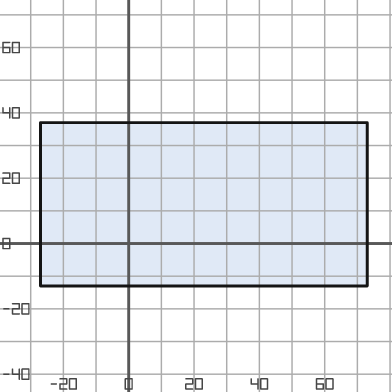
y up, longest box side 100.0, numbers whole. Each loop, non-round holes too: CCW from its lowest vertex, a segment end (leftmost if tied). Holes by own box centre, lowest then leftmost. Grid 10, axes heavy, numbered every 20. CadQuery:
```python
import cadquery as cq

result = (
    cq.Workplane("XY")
    .moveTo(-27.0, -13.0)
    .lineTo(73.0, -13.0)
    .lineTo(73.0, 37.0)
    .lineTo(-27.0, 37.0)
    .close()
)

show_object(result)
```